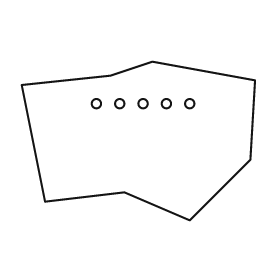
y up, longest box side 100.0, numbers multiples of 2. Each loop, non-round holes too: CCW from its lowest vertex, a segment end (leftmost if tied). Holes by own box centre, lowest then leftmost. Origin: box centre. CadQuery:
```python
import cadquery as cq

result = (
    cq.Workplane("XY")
    .moveTo(22.0, -34.0)
    .lineTo(48.0, -8.0)
    .lineTo(50.0, 26.0)
    .lineTo(6.0, 34.0)
    .lineTo(-12.0, 28.0)
    .lineTo(-50.0, 24.0)
    .lineTo(-40.0, -26.0)
    .lineTo(-6.0, -22.0)
    .close()
    .moveTo(-18.0, 16.0)
    .circle(2.0)
    .moveTo(-8.0, 16.0)
    .circle(2.0)
    .moveTo(2.0, 16.0)
    .circle(2.0)
    .moveTo(12.0, 16.0)
    .circle(2.0)
    .moveTo(22.0, 16.0)
    .circle(2.0)
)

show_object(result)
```